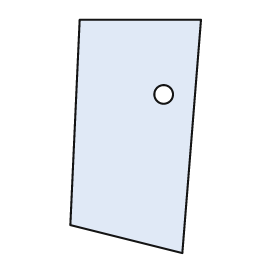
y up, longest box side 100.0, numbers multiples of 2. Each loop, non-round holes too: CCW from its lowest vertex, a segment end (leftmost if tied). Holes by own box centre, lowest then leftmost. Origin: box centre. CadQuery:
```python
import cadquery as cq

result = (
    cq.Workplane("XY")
    .moveTo(20.0, -50.0)
    .lineTo(28.0, 50.0)
    .lineTo(-24.0, 50.0)
    .lineTo(-28.0, -38.0)
    .close()
    .moveTo(12.0, 18.0)
    .circle(4.0)
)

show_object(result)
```